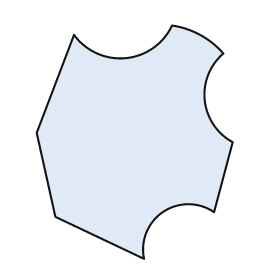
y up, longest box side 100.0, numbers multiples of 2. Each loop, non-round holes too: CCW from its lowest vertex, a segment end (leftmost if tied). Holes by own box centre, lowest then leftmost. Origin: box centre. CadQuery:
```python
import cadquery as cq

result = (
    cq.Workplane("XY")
    .moveTo(4.0, -50.0)
    .threePointArc((12.0, -30.0), (34.0, -30.0))
    .lineTo(42.0, 0.0)
    .threePointArc((30.0, 18.0), (38.0, 38.0))
    .threePointArc((28.0, 46.0), (16.0, 50.0))
    .threePointArc((-4.0, 36.0), (-26.0, 46.0))
    .lineTo(-42.0, 4.0)
    .lineTo(-34.0, -32.0)
    .close()
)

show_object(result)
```